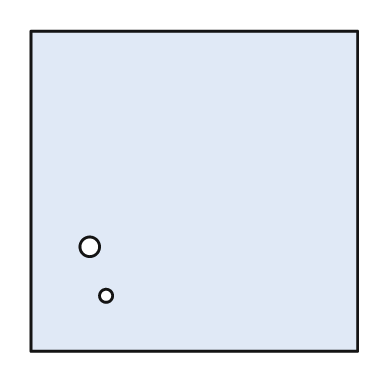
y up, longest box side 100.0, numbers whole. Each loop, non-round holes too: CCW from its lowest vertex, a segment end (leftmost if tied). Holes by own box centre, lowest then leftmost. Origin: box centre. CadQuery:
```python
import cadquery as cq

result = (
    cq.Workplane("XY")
    .moveTo(-50.0, -49.0)
    .lineTo(50.0, -49.0)
    .lineTo(50.0, 49.0)
    .lineTo(-50.0, 49.0)
    .close()
    .moveTo(-27.0, -32.0)
    .circle(2.0)
    .moveTo(-32.0, -17.0)
    .circle(3.0)
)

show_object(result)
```